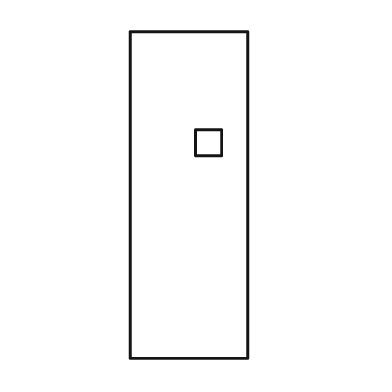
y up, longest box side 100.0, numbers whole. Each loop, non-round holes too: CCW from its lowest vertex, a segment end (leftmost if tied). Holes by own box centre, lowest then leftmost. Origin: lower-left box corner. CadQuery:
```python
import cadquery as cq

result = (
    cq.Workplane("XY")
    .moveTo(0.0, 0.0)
    .lineTo(36.0, 0.0)
    .lineTo(36.0, 100.0)
    .lineTo(0.0, 100.0)
    .close()
    .moveTo(20.0, 62.0)
    .lineTo(28.0, 62.0)
    .lineTo(28.0, 70.0)
    .lineTo(20.0, 70.0)
    .close()
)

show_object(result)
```